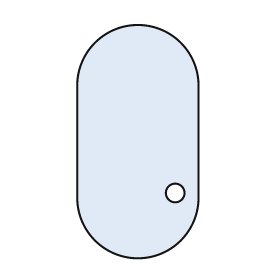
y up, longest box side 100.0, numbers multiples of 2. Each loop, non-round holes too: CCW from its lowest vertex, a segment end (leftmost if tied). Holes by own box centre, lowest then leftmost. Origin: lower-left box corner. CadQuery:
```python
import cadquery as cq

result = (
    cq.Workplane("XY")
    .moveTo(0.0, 26.0)
    .threePointArc((26.0, 0.0), (52.0, 26.0))
    .lineTo(52.0, 74.0)
    .threePointArc((26.0, 100.0), (0.0, 74.0))
    .close()
    .moveTo(42.0, 28.0)
    .circle(4.0)
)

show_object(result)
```